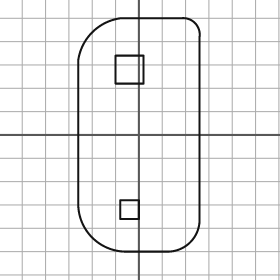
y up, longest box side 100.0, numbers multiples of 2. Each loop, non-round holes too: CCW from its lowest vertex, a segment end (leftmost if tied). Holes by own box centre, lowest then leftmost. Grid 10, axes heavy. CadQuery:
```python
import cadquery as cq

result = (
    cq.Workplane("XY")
    .moveTo(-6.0, -50.0)
    .lineTo(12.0, -50.0)
    .threePointArc((22.0, -46.0), (26.0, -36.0))
    .lineTo(26.0, 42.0)
    .threePointArc((24.0, 48.0), (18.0, 50.0))
    .lineTo(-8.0, 50.0)
    .threePointArc((-20.0, 44.0), (-26.0, 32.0))
    .lineTo(-26.0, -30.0)
    .threePointArc((-20.0, -44.0), (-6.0, -50.0))
    .close()
    .moveTo(-8.0, -36.0)
    .lineTo(0.0, -36.0)
    .lineTo(0.0, -28.0)
    .lineTo(-8.0, -28.0)
    .close()
    .moveTo(-10.0, 22.0)
    .lineTo(2.0, 22.0)
    .lineTo(2.0, 34.0)
    .lineTo(-10.0, 34.0)
    .close()
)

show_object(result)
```